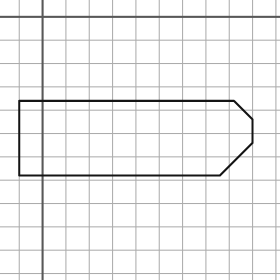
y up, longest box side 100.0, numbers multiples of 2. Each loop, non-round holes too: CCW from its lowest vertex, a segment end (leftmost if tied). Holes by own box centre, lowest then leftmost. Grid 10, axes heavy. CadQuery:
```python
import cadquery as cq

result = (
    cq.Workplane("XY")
    .moveTo(-10.0, -68.0)
    .lineTo(76.0, -68.0)
    .lineTo(90.0, -54.0)
    .lineTo(90.0, -44.0)
    .lineTo(82.0, -36.0)
    .lineTo(-10.0, -36.0)
    .close()
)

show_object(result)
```